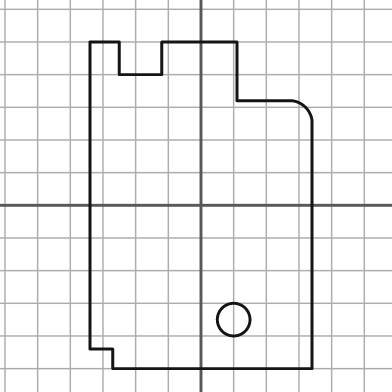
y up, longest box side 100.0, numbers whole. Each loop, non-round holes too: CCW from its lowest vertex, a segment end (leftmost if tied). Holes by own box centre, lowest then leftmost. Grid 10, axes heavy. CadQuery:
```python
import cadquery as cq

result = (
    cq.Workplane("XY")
    .moveTo(-27.0, -50.0)
    .lineTo(34.0, -50.0)
    .lineTo(34.0, 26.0)
    .threePointArc((32.0, 30.0), (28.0, 32.0))
    .lineTo(11.0, 32.0)
    .lineTo(11.0, 50.0)
    .lineTo(-12.0, 50.0)
    .lineTo(-12.0, 40.0)
    .lineTo(-25.0, 40.0)
    .lineTo(-25.0, 50.0)
    .lineTo(-34.0, 50.0)
    .lineTo(-34.0, -44.0)
    .lineTo(-27.0, -44.0)
    .close()
    .moveTo(10.0, -35.0)
    .circle(5.0)
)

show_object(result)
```